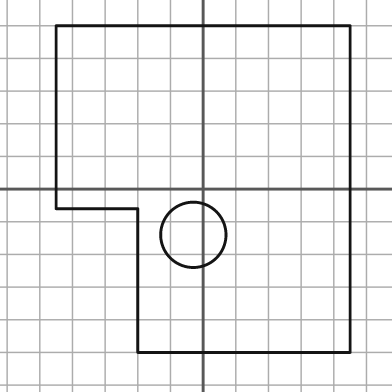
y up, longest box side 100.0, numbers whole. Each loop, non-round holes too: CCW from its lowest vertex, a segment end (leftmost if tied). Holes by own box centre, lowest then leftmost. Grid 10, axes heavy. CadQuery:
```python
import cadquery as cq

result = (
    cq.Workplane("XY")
    .moveTo(-20.0, -50.0)
    .lineTo(45.0, -50.0)
    .lineTo(45.0, 50.0)
    .lineTo(-45.0, 50.0)
    .lineTo(-45.0, -6.0)
    .lineTo(-20.0, -6.0)
    .close()
    .moveTo(-3.0, -14.0)
    .circle(10.0)
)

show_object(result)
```